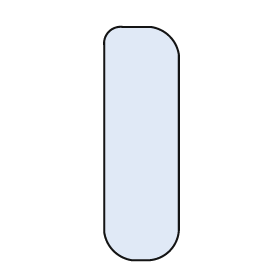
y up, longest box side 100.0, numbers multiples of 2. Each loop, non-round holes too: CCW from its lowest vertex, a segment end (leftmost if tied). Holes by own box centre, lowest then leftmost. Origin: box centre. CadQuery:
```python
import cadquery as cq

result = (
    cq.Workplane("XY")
    .moveTo(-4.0, -50.0)
    .lineTo(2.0, -50.0)
    .threePointArc((12.0, -46.0), (16.0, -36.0))
    .lineTo(16.0, 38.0)
    .threePointArc((12.0, 46.0), (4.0, 50.0))
    .lineTo(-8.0, 50.0)
    .threePointArc((-14.0, 48.0), (-16.0, 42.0))
    .lineTo(-16.0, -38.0)
    .threePointArc((-12.0, -46.0), (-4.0, -50.0))
    .close()
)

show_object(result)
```